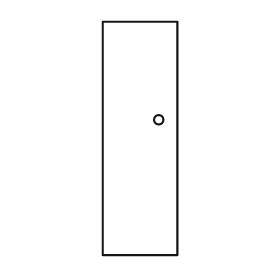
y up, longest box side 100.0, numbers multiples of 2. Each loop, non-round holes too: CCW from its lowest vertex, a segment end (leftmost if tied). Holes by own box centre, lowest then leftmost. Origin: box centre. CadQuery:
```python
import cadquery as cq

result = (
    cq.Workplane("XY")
    .moveTo(-16.0, -50.0)
    .lineTo(16.0, -50.0)
    .lineTo(16.0, 50.0)
    .lineTo(-16.0, 50.0)
    .close()
    .moveTo(8.0, 8.0)
    .circle(2.0)
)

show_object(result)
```